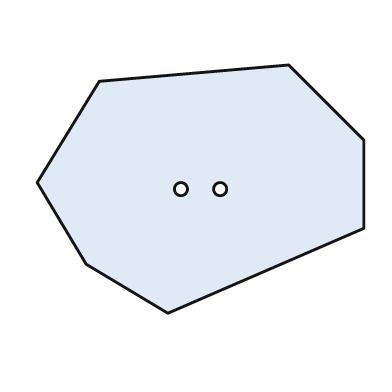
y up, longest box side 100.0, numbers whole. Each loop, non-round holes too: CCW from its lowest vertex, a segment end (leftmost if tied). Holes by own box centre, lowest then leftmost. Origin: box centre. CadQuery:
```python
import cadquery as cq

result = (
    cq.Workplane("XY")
    .moveTo(-10.0, -38.0)
    .lineTo(50.0, -12.0)
    .lineTo(50.0, 15.0)
    .lineTo(27.0, 38.0)
    .lineTo(-31.0, 33.0)
    .lineTo(-50.0, 2.0)
    .lineTo(-35.0, -23.0)
    .close()
    .moveTo(-6.0, 0.0)
    .circle(2.0)
    .moveTo(6.0, 0.0)
    .circle(2.0)
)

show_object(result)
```